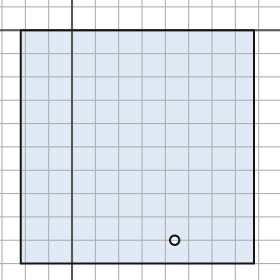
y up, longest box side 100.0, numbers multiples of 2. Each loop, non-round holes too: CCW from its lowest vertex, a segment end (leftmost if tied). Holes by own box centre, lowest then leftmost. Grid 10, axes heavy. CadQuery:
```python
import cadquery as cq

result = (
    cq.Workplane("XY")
    .moveTo(-22.0, -100.0)
    .lineTo(78.0, -100.0)
    .lineTo(78.0, 0.0)
    .lineTo(-22.0, 0.0)
    .close()
    .moveTo(44.0, -90.0)
    .circle(2.0)
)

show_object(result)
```